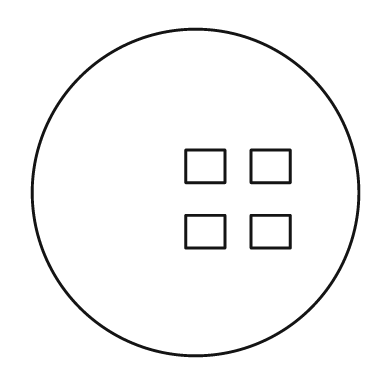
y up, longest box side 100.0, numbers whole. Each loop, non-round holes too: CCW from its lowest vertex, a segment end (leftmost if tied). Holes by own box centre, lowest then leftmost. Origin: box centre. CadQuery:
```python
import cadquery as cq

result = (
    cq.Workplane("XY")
    .moveTo(0.0, 0.0)
    .circle(50.0)
    .moveTo(-3.0, -17.0)
    .lineTo(9.0, -17.0)
    .lineTo(9.0, -7.0)
    .lineTo(-3.0, -7.0)
    .close()
    .moveTo(17.0, -17.0)
    .lineTo(29.0, -17.0)
    .lineTo(29.0, -7.0)
    .lineTo(17.0, -7.0)
    .close()
    .moveTo(-3.0, 3.0)
    .lineTo(9.0, 3.0)
    .lineTo(9.0, 13.0)
    .lineTo(-3.0, 13.0)
    .close()
    .moveTo(17.0, 3.0)
    .lineTo(29.0, 3.0)
    .lineTo(29.0, 13.0)
    .lineTo(17.0, 13.0)
    .close()
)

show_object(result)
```